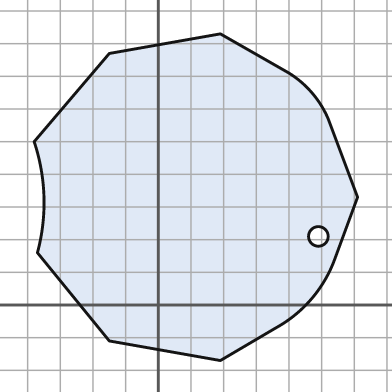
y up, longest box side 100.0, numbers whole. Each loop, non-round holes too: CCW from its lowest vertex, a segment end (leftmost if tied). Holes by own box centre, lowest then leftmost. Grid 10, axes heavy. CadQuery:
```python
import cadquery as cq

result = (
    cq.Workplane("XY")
    .moveTo(19.0, -17.0)
    .lineTo(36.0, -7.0)
    .threePointArc((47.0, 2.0), (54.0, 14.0))
    .lineTo(61.0, 33.0)
    .lineTo(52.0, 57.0)
    .threePointArc((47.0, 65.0), (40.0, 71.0))
    .lineTo(19.0, 83.0)
    .lineTo(-15.0, 77.0)
    .lineTo(-38.0, 50.0)
    .threePointArc((-35.0, 33.0), (-37.0, 16.0))
    .lineTo(-15.0, -11.0)
    .close()
    .moveTo(49.0, 21.0)
    .circle(3.0)
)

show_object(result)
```